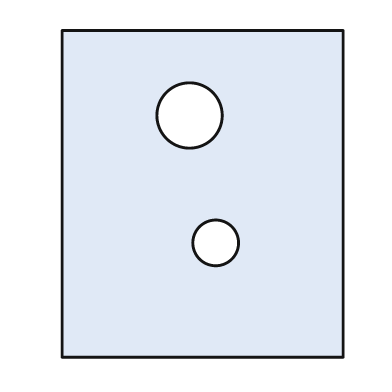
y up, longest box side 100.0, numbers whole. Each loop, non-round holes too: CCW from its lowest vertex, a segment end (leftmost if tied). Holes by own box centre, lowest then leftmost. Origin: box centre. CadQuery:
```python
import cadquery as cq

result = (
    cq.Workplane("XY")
    .moveTo(-43.0, -50.0)
    .lineTo(43.0, -50.0)
    .lineTo(43.0, 50.0)
    .lineTo(-43.0, 50.0)
    .close()
    .moveTo(4.0, -15.0)
    .circle(7.0)
    .moveTo(-4.0, 24.0)
    .circle(10.0)
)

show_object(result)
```